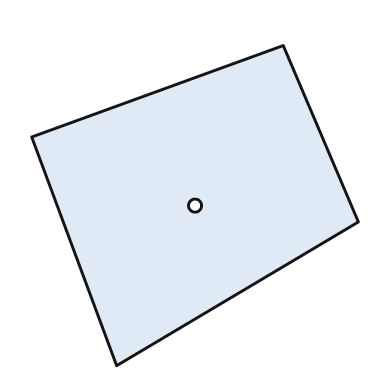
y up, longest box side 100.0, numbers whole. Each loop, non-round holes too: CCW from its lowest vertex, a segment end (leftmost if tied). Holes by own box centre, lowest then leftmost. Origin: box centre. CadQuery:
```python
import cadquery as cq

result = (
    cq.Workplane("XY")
    .moveTo(-24.0, -49.0)
    .lineTo(50.0, -5.0)
    .lineTo(27.0, 49.0)
    .lineTo(-50.0, 21.0)
    .close()
    .moveTo(0.0, 0.0)
    .circle(2.0)
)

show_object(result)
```